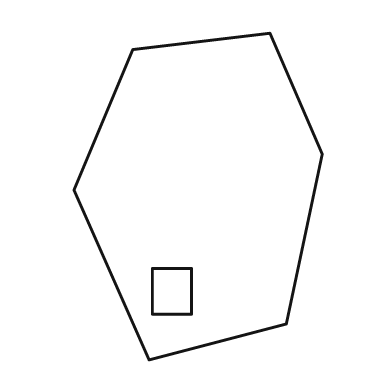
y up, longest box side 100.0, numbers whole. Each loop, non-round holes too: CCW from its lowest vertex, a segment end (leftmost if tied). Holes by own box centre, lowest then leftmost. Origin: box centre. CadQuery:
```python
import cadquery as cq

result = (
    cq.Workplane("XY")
    .moveTo(-15.0, -50.0)
    .lineTo(27.0, -39.0)
    .lineTo(38.0, 13.0)
    .lineTo(22.0, 50.0)
    .lineTo(-20.0, 45.0)
    .lineTo(-38.0, 2.0)
    .close()
    .moveTo(-14.0, -36.0)
    .lineTo(-2.0, -36.0)
    .lineTo(-2.0, -22.0)
    .lineTo(-14.0, -22.0)
    .close()
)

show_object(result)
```